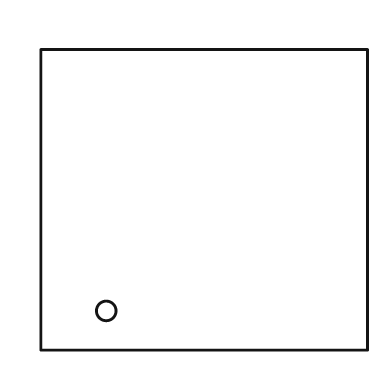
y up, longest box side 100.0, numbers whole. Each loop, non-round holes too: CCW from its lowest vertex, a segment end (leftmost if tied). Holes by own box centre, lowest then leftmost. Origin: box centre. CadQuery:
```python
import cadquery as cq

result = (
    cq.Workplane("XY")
    .moveTo(-50.0, -46.0)
    .lineTo(50.0, -46.0)
    .lineTo(50.0, 46.0)
    .lineTo(-50.0, 46.0)
    .close()
    .moveTo(-30.0, -34.0)
    .circle(3.0)
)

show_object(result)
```